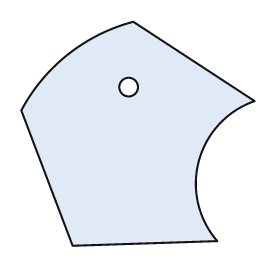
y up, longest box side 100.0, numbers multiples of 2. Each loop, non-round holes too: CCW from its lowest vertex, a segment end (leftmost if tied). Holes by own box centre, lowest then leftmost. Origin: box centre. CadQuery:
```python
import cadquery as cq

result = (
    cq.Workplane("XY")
    .moveTo(-28.0, -48.0)
    .lineTo(34.0, -46.0)
    .threePointArc((26.0, -12.0), (50.0, 14.0))
    .lineTo(-2.0, 48.0)
    .threePointArc((-30.0, 34.0), (-50.0, 10.0))
    .close()
    .moveTo(-4.0, 20.0)
    .circle(4.0)
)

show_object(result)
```